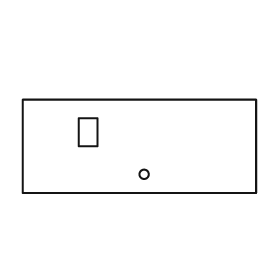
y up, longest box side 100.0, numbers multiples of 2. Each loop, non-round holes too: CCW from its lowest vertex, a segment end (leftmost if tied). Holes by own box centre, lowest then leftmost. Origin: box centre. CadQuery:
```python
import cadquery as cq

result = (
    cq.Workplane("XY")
    .moveTo(-50.0, -20.0)
    .lineTo(50.0, -20.0)
    .lineTo(50.0, 20.0)
    .lineTo(-50.0, 20.0)
    .close()
    .moveTo(2.0, -12.0)
    .circle(2.0)
    .moveTo(-26.0, 0.0)
    .lineTo(-18.0, 0.0)
    .lineTo(-18.0, 12.0)
    .lineTo(-26.0, 12.0)
    .close()
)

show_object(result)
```